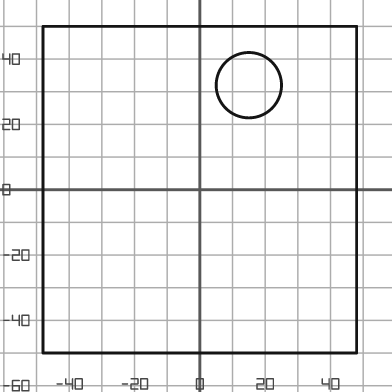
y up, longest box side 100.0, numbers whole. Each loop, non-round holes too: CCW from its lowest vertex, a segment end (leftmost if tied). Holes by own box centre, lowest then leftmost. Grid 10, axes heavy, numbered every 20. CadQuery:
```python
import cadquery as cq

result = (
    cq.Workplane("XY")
    .moveTo(-48.0, -50.0)
    .lineTo(48.0, -50.0)
    .lineTo(48.0, 50.0)
    .lineTo(-48.0, 50.0)
    .close()
    .moveTo(15.0, 32.0)
    .circle(10.0)
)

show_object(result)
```